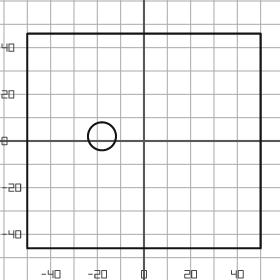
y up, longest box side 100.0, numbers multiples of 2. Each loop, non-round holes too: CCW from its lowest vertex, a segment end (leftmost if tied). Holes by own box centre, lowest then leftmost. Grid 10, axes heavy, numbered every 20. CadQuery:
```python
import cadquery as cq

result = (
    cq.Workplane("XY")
    .moveTo(-50.0, -46.0)
    .lineTo(50.0, -46.0)
    .lineTo(50.0, 46.0)
    .lineTo(-50.0, 46.0)
    .close()
    .moveTo(-18.0, 2.0)
    .circle(6.0)
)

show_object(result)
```